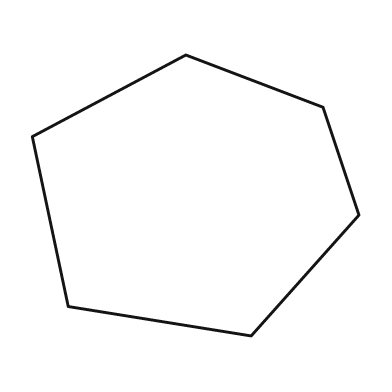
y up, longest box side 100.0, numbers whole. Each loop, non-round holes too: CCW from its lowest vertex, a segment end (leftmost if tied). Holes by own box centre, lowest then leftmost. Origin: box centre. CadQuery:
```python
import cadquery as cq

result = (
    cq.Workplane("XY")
    .moveTo(17.0, -43.0)
    .lineTo(50.0, -6.0)
    .lineTo(39.0, 27.0)
    .lineTo(-3.0, 43.0)
    .lineTo(-50.0, 18.0)
    .lineTo(-39.0, -34.0)
    .close()
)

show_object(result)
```